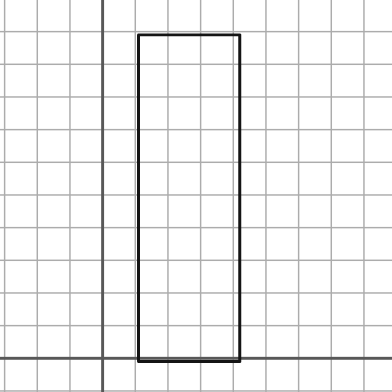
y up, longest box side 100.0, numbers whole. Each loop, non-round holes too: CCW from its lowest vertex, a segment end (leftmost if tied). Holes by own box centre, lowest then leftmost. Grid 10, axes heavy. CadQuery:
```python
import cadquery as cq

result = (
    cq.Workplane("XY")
    .moveTo(11.0, -1.0)
    .lineTo(42.0, -1.0)
    .lineTo(42.0, 99.0)
    .lineTo(11.0, 99.0)
    .close()
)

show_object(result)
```